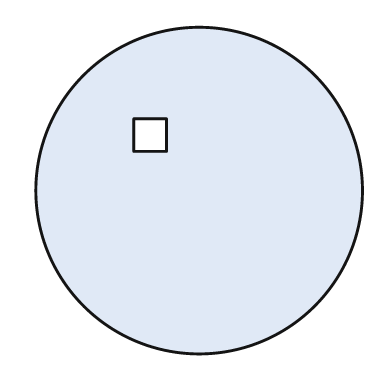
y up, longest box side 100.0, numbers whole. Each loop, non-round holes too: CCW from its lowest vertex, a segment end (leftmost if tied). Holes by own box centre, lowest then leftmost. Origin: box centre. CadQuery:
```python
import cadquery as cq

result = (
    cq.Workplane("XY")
    .moveTo(0.0, 0.0)
    .circle(50.0)
    .moveTo(-20.0, 12.0)
    .lineTo(-10.0, 12.0)
    .lineTo(-10.0, 22.0)
    .lineTo(-20.0, 22.0)
    .close()
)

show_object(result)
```